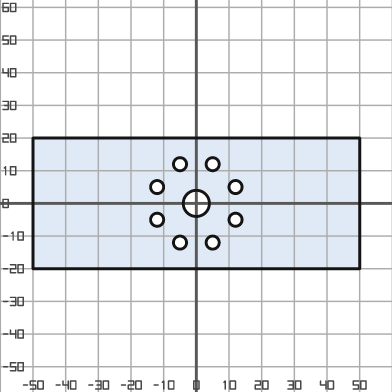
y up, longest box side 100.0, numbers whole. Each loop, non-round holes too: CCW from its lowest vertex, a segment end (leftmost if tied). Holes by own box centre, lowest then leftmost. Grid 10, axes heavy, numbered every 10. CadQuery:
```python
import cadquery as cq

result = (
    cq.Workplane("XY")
    .moveTo(-50.0, -20.0)
    .lineTo(50.0, -20.0)
    .lineTo(50.0, 20.0)
    .lineTo(-50.0, 20.0)
    .close()
    .moveTo(-5.0, -12.0)
    .circle(2.0)
    .moveTo(5.0, -12.0)
    .circle(2.0)
    .moveTo(-12.0, -5.0)
    .circle(2.0)
    .moveTo(12.0, -5.0)
    .circle(2.0)
    .moveTo(0.0, 0.0)
    .circle(4.0)
    .moveTo(-12.0, 5.0)
    .circle(2.0)
    .moveTo(12.0, 5.0)
    .circle(2.0)
    .moveTo(-5.0, 12.0)
    .circle(2.0)
    .moveTo(5.0, 12.0)
    .circle(2.0)
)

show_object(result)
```